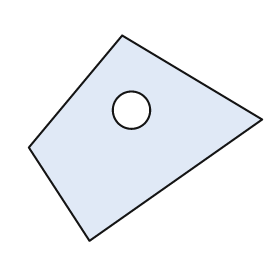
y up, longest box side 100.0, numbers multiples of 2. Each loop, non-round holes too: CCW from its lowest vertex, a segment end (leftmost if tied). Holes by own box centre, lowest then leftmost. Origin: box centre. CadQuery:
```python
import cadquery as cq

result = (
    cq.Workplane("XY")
    .moveTo(-24.0, -44.0)
    .lineTo(50.0, 8.0)
    .lineTo(-10.0, 44.0)
    .lineTo(-50.0, -4.0)
    .close()
    .moveTo(-6.0, 12.0)
    .circle(8.0)
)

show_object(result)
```